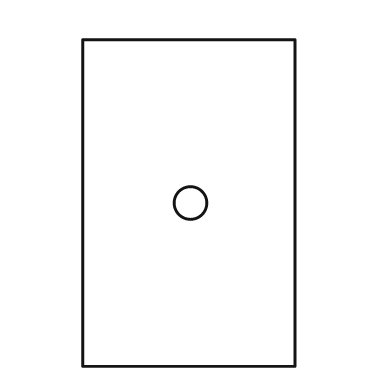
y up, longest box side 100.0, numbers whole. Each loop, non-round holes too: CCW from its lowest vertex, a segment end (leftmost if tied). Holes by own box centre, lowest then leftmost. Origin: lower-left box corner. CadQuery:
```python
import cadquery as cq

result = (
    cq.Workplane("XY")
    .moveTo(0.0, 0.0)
    .lineTo(65.0, 0.0)
    .lineTo(65.0, 100.0)
    .lineTo(0.0, 100.0)
    .close()
    .moveTo(33.0, 50.0)
    .circle(5.0)
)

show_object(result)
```